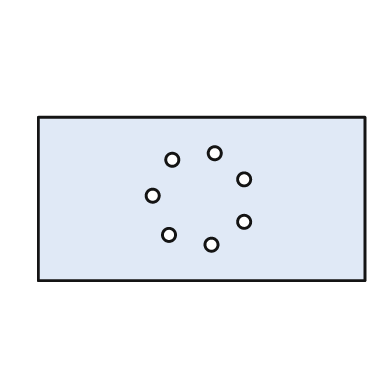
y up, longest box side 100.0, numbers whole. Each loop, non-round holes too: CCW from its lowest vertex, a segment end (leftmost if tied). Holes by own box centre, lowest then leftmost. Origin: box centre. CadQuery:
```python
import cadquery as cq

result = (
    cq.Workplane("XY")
    .moveTo(-50.0, -25.0)
    .lineTo(50.0, -25.0)
    .lineTo(50.0, 25.0)
    .lineTo(-50.0, 25.0)
    .close()
    .moveTo(3.0, -14.0)
    .circle(2.0)
    .moveTo(-10.0, -11.0)
    .circle(2.0)
    .moveTo(13.0, -7.0)
    .circle(2.0)
    .moveTo(-15.0, 1.0)
    .circle(2.0)
    .moveTo(13.0, 6.0)
    .circle(2.0)
    .moveTo(-9.0, 12.0)
    .circle(2.0)
    .moveTo(4.0, 14.0)
    .circle(2.0)
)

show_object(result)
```